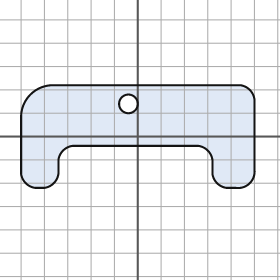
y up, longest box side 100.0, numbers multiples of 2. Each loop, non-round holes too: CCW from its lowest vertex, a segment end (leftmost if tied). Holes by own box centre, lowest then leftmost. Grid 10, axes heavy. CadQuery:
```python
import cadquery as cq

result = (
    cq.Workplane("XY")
    .moveTo(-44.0, -22.0)
    .lineTo(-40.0, -22.0)
    .threePointArc((-36.0, -20.0), (-34.0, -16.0))
    .lineTo(-34.0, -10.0)
    .threePointArc((-32.0, -6.0), (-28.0, -4.0))
    .lineTo(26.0, -4.0)
    .threePointArc((30.0, -6.0), (32.0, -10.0))
    .lineTo(32.0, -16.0)
    .threePointArc((34.0, -20.0), (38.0, -22.0))
    .lineTo(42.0, -22.0)
    .threePointArc((48.0, -20.0), (50.0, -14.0))
    .lineTo(50.0, 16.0)
    .threePointArc((48.0, 20.0), (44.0, 22.0))
    .lineTo(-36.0, 22.0)
    .threePointArc((-46.0, 18.0), (-50.0, 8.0))
    .lineTo(-50.0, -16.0)
    .threePointArc((-48.0, -20.0), (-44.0, -22.0))
    .close()
    .moveTo(-4.0, 14.0)
    .circle(4.0)
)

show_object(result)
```